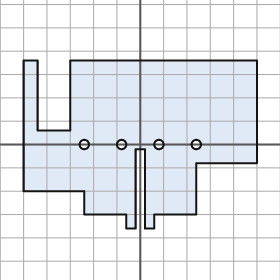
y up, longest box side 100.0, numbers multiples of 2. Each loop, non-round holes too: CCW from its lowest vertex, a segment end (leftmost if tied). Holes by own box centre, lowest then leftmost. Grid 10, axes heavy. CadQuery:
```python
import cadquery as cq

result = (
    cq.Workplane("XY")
    .moveTo(-6.0, -36.0)
    .lineTo(-2.0, -36.0)
    .lineTo(-2.0, -2.0)
    .lineTo(2.0, -2.0)
    .lineTo(2.0, -36.0)
    .lineTo(6.0, -36.0)
    .lineTo(6.0, -30.0)
    .lineTo(24.0, -30.0)
    .lineTo(24.0, -8.0)
    .lineTo(50.0, -8.0)
    .lineTo(50.0, 36.0)
    .lineTo(-30.0, 36.0)
    .lineTo(-30.0, 6.0)
    .lineTo(-44.0, 6.0)
    .lineTo(-44.0, 36.0)
    .lineTo(-50.0, 36.0)
    .lineTo(-50.0, -20.0)
    .lineTo(-24.0, -20.0)
    .lineTo(-24.0, -30.0)
    .lineTo(-6.0, -30.0)
    .close()
    .moveTo(-24.0, 0.0)
    .circle(2.0)
    .moveTo(-8.0, 0.0)
    .circle(2.0)
    .moveTo(8.0, 0.0)
    .circle(2.0)
    .moveTo(24.0, 0.0)
    .circle(2.0)
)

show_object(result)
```